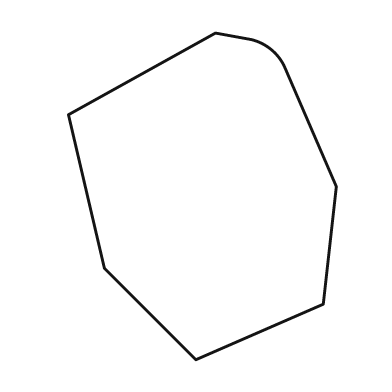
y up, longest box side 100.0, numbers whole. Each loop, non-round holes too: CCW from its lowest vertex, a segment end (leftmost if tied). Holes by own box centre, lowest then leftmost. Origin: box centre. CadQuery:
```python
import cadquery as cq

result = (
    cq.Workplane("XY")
    .moveTo(-2.0, -50.0)
    .lineTo(37.0, -33.0)
    .lineTo(41.0, 3.0)
    .lineTo(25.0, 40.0)
    .threePointArc((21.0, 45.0), (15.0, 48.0))
    .lineTo(4.0, 50.0)
    .lineTo(-41.0, 25.0)
    .lineTo(-30.0, -22.0)
    .close()
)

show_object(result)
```